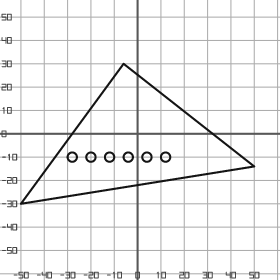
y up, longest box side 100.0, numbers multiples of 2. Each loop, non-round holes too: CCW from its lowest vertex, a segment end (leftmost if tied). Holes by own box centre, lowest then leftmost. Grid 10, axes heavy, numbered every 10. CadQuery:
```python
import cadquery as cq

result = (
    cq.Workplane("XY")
    .moveTo(-50.0, -30.0)
    .lineTo(50.0, -14.0)
    .lineTo(-6.0, 30.0)
    .close()
    .moveTo(-28.0, -10.0)
    .circle(2.0)
    .moveTo(-20.0, -10.0)
    .circle(2.0)
    .moveTo(-12.0, -10.0)
    .circle(2.0)
    .moveTo(-4.0, -10.0)
    .circle(2.0)
    .moveTo(4.0, -10.0)
    .circle(2.0)
    .moveTo(12.0, -10.0)
    .circle(2.0)
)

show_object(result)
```